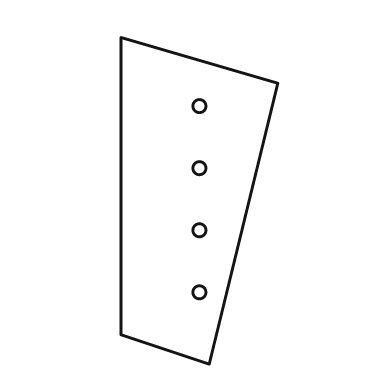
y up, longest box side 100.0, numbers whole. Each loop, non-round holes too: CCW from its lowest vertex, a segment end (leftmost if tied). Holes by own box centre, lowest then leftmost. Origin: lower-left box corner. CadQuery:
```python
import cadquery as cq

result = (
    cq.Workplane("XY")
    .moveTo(27.0, 0.0)
    .lineTo(48.0, 86.0)
    .lineTo(0.0, 100.0)
    .lineTo(0.0, 9.0)
    .close()
    .moveTo(24.0, 22.0)
    .circle(2.0)
    .moveTo(24.0, 41.0)
    .circle(2.0)
    .moveTo(24.0, 60.0)
    .circle(2.0)
    .moveTo(24.0, 79.0)
    .circle(2.0)
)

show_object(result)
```